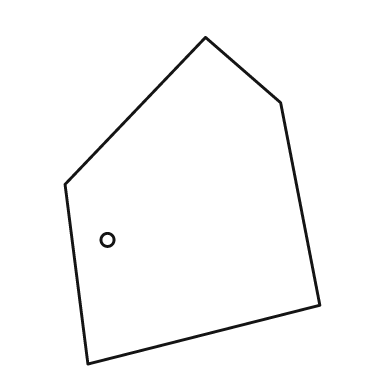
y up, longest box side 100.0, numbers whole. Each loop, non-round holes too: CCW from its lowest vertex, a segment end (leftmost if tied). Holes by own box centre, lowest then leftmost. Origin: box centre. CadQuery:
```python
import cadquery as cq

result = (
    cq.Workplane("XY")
    .moveTo(-32.0, -50.0)
    .lineTo(39.0, -32.0)
    .lineTo(27.0, 30.0)
    .lineTo(4.0, 50.0)
    .lineTo(-39.0, 5.0)
    .close()
    .moveTo(-26.0, -12.0)
    .circle(2.0)
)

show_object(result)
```